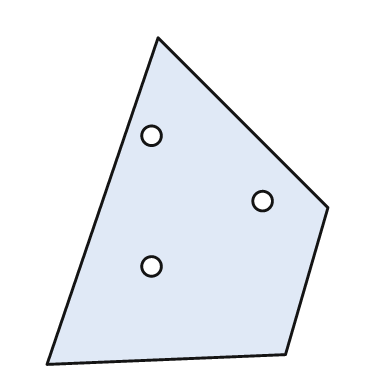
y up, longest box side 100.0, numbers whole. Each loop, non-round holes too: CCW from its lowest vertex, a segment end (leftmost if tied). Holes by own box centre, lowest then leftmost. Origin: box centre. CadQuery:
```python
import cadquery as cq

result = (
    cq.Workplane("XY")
    .moveTo(-43.0, -50.0)
    .lineTo(30.0, -47.0)
    .lineTo(43.0, -2.0)
    .lineTo(-9.0, 50.0)
    .close()
    .moveTo(-11.0, -20.0)
    .circle(3.0)
    .moveTo(23.0, 0.0)
    .circle(3.0)
    .moveTo(-11.0, 20.0)
    .circle(3.0)
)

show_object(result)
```